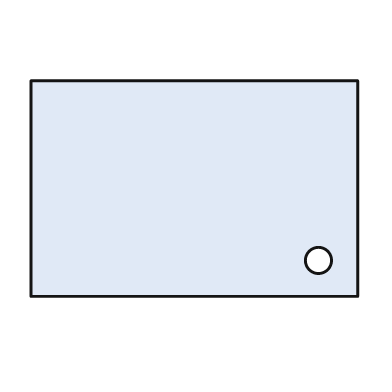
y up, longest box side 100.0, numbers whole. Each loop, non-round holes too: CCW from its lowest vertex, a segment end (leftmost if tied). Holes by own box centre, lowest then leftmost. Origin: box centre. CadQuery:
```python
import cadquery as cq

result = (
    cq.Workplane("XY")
    .moveTo(-50.0, -33.0)
    .lineTo(50.0, -33.0)
    .lineTo(50.0, 33.0)
    .lineTo(-50.0, 33.0)
    .close()
    .moveTo(38.0, -22.0)
    .circle(4.0)
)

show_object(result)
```